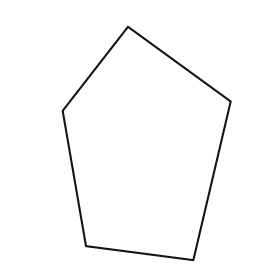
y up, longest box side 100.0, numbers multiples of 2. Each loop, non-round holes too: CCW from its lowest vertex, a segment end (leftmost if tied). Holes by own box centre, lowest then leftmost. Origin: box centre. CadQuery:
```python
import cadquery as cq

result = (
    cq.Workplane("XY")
    .moveTo(20.0, -50.0)
    .lineTo(36.0, 18.0)
    .lineTo(-8.0, 50.0)
    .lineTo(-36.0, 14.0)
    .lineTo(-26.0, -44.0)
    .close()
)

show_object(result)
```